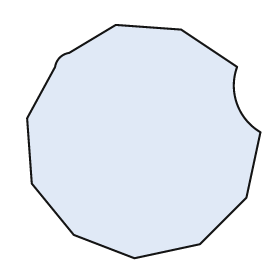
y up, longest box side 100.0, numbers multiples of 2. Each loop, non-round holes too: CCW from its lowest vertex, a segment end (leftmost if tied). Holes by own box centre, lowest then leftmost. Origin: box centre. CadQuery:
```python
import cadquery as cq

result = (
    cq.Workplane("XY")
    .moveTo(-4.0, -50.0)
    .lineTo(24.0, -44.0)
    .lineTo(44.0, -24.0)
    .lineTo(50.0, 4.0)
    .threePointArc((40.0, 16.0), (40.0, 32.0))
    .lineTo(16.0, 48.0)
    .lineTo(-12.0, 50.0)
    .lineTo(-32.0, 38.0)
    .threePointArc((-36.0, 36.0), (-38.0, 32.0))
    .lineTo(-50.0, 10.0)
    .lineTo(-48.0, -18.0)
    .lineTo(-30.0, -40.0)
    .close()
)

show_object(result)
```